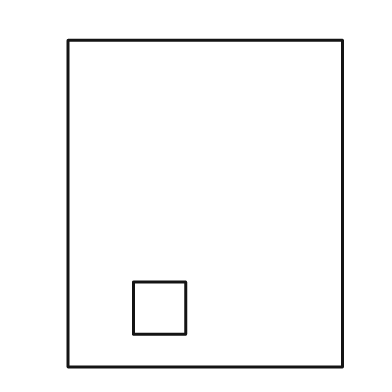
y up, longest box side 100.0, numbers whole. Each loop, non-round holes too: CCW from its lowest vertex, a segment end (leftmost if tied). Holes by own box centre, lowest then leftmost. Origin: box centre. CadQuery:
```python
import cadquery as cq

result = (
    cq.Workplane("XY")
    .moveTo(-42.0, -50.0)
    .lineTo(42.0, -50.0)
    .lineTo(42.0, 50.0)
    .lineTo(-42.0, 50.0)
    .close()
    .moveTo(-22.0, -40.0)
    .lineTo(-6.0, -40.0)
    .lineTo(-6.0, -24.0)
    .lineTo(-22.0, -24.0)
    .close()
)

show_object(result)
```